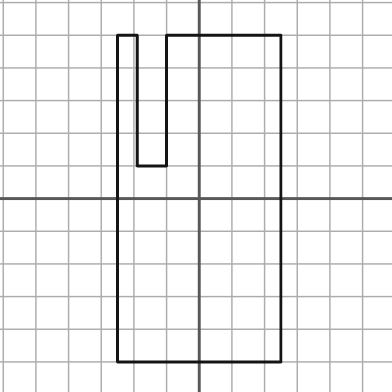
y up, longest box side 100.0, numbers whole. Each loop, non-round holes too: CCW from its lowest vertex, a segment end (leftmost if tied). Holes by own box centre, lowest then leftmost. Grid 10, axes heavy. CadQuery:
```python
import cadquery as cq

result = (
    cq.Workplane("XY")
    .moveTo(-25.0, -50.0)
    .lineTo(25.0, -50.0)
    .lineTo(25.0, 50.0)
    .lineTo(-10.0, 50.0)
    .lineTo(-10.0, 10.0)
    .lineTo(-19.0, 10.0)
    .lineTo(-19.0, 50.0)
    .lineTo(-25.0, 50.0)
    .close()
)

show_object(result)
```